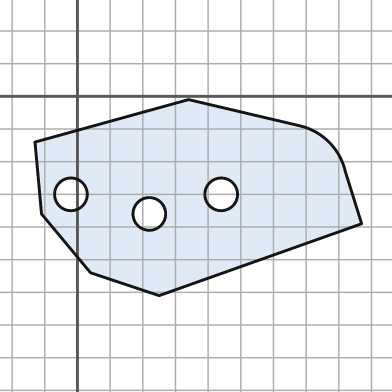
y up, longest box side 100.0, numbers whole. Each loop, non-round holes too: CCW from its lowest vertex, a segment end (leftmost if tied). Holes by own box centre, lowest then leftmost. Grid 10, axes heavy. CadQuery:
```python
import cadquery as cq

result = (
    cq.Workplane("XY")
    .moveTo(25.0, -61.0)
    .lineTo(87.0, -39.0)
    .lineTo(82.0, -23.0)
    .threePointArc((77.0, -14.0), (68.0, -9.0))
    .lineTo(34.0, -1.0)
    .lineTo(-13.0, -14.0)
    .lineTo(-11.0, -36.0)
    .lineTo(4.0, -54.0)
    .close()
    .moveTo(22.0, -36.0)
    .circle(5.0)
    .moveTo(-2.0, -30.0)
    .circle(5.0)
    .moveTo(44.0, -30.0)
    .circle(5.0)
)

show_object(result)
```